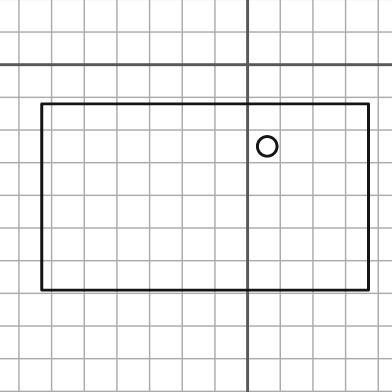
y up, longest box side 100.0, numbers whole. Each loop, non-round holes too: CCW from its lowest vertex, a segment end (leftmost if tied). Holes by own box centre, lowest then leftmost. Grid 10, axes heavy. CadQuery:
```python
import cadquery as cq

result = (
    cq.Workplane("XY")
    .moveTo(-63.0, -69.0)
    .lineTo(37.0, -69.0)
    .lineTo(37.0, -12.0)
    .lineTo(-63.0, -12.0)
    .close()
    .moveTo(6.0, -25.0)
    .circle(3.0)
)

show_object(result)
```